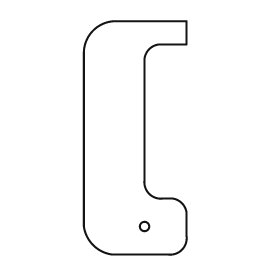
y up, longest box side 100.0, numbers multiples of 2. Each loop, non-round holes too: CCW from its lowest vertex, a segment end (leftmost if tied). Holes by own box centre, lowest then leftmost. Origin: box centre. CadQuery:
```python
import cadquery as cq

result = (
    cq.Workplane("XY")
    .moveTo(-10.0, -50.0)
    .lineTo(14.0, -50.0)
    .threePointArc((20.0, -48.0), (22.0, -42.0))
    .lineTo(22.0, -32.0)
    .threePointArc((20.0, -28.0), (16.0, -26.0))
    .lineTo(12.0, -26.0)
    .threePointArc((6.0, -24.0), (4.0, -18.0))
    .lineTo(4.0, 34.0)
    .threePointArc((6.0, 38.0), (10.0, 40.0))
    .lineTo(22.0, 40.0)
    .lineTo(22.0, 50.0)
    .lineTo(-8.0, 50.0)
    .threePointArc((-18.0, 46.0), (-22.0, 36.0))
    .lineTo(-22.0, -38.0)
    .threePointArc((-18.0, -46.0), (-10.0, -50.0))
    .close()
    .moveTo(4.0, -38.0)
    .circle(2.0)
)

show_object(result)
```